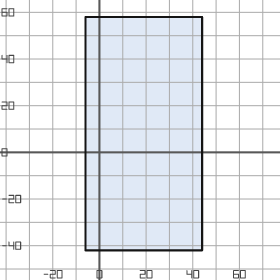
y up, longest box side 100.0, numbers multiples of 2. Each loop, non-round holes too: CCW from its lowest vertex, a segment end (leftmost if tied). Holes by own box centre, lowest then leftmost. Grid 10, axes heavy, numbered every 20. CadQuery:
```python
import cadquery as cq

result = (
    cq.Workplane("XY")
    .moveTo(-6.0, -42.0)
    .lineTo(44.0, -42.0)
    .lineTo(44.0, 58.0)
    .lineTo(-6.0, 58.0)
    .close()
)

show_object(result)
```